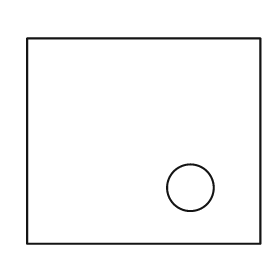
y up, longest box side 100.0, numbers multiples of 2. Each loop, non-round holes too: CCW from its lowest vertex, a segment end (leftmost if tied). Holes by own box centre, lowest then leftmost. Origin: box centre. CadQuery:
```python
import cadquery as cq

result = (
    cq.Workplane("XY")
    .moveTo(-50.0, -44.0)
    .lineTo(50.0, -44.0)
    .lineTo(50.0, 44.0)
    .lineTo(-50.0, 44.0)
    .close()
    .moveTo(20.0, -20.0)
    .circle(10.0)
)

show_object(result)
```